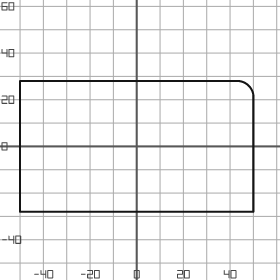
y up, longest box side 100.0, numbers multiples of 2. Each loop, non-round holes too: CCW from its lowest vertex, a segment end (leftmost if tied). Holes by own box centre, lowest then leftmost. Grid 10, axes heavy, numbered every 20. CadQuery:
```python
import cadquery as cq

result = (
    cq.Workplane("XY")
    .moveTo(-50.0, -28.0)
    .lineTo(50.0, -28.0)
    .lineTo(50.0, 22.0)
    .threePointArc((48.0, 26.0), (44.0, 28.0))
    .lineTo(-50.0, 28.0)
    .close()
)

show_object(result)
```